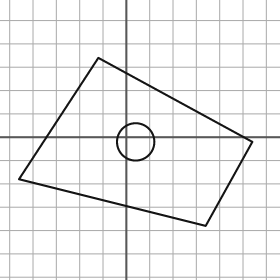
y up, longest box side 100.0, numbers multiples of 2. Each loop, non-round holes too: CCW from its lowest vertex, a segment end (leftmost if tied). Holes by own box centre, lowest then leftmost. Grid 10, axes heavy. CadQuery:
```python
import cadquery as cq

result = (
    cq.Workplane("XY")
    .moveTo(34.0, -38.0)
    .lineTo(54.0, -2.0)
    .lineTo(-12.0, 34.0)
    .lineTo(-46.0, -18.0)
    .close()
    .moveTo(4.0, -2.0)
    .circle(8.0)
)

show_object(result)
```